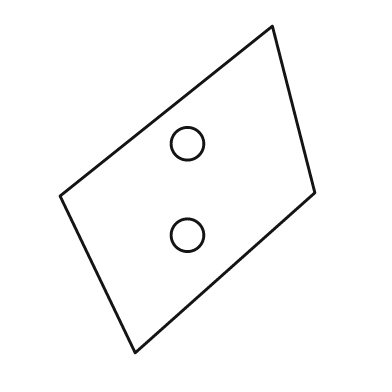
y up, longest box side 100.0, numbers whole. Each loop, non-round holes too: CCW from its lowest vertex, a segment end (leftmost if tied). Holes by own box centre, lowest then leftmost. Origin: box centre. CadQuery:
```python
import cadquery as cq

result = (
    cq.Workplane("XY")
    .moveTo(-16.0, -50.0)
    .lineTo(39.0, -1.0)
    .lineTo(26.0, 50.0)
    .lineTo(-39.0, -2.0)
    .close()
    .moveTo(0.0, -14.0)
    .circle(5.0)
    .moveTo(0.0, 14.0)
    .circle(5.0)
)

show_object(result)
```